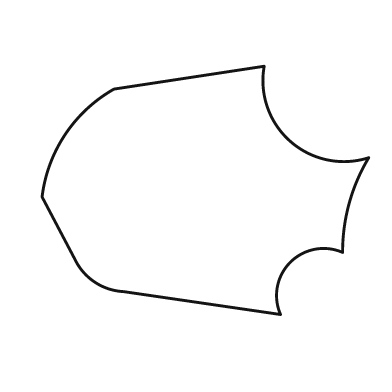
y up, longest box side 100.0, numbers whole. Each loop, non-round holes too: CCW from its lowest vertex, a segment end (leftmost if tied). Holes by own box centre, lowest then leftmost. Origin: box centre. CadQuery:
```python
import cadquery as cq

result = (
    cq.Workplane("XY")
    .moveTo(23.0, -38.0)
    .threePointArc((26.0, -22.0), (42.0, -19.0))
    .threePointArc((44.0, -4.0), (50.0, 10.0))
    .threePointArc((26.0, 15.0), (18.0, 38.0))
    .lineTo(-28.0, 31.0)
    .threePointArc((-43.0, 17.0), (-50.0, -2.0))
    .lineTo(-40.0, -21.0)
    .threePointArc((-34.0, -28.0), (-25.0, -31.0))
    .close()
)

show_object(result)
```